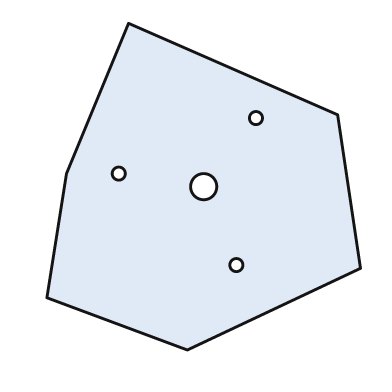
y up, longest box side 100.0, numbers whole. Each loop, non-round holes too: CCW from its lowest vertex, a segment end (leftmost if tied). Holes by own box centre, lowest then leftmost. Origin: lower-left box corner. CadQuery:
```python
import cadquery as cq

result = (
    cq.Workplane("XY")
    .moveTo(43.0, 0.0)
    .lineTo(96.0, 25.0)
    .lineTo(89.0, 72.0)
    .lineTo(25.0, 100.0)
    .lineTo(6.0, 54.0)
    .lineTo(0.0, 16.0)
    .close()
    .moveTo(58.0, 26.0)
    .circle(2.0)
    .moveTo(48.0, 50.0)
    .circle(4.0)
    .moveTo(22.0, 54.0)
    .circle(2.0)
    .moveTo(64.0, 71.0)
    .circle(2.0)
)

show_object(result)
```